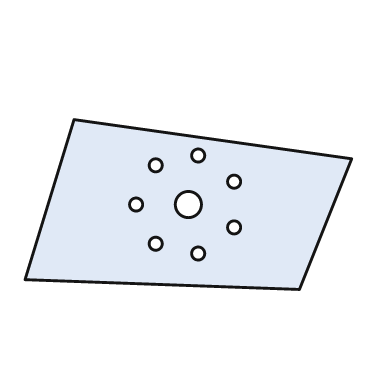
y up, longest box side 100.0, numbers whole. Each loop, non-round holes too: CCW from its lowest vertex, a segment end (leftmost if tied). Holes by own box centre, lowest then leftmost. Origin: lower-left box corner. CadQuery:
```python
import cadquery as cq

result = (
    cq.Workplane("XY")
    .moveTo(84.0, 0.0)
    .lineTo(100.0, 40.0)
    .lineTo(15.0, 52.0)
    .lineTo(0.0, 3.0)
    .close()
    .moveTo(53.0, 11.0)
    .circle(2.0)
    .moveTo(40.0, 14.0)
    .circle(2.0)
    .moveTo(64.0, 19.0)
    .circle(2.0)
    .moveTo(34.0, 26.0)
    .circle(2.0)
    .moveTo(50.0, 26.0)
    .circle(4.0)
    .moveTo(64.0, 33.0)
    .circle(2.0)
    .moveTo(40.0, 38.0)
    .circle(2.0)
    .moveTo(53.0, 41.0)
    .circle(2.0)
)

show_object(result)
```